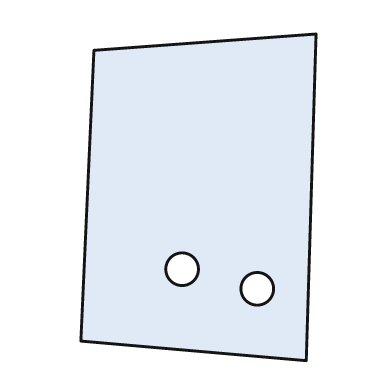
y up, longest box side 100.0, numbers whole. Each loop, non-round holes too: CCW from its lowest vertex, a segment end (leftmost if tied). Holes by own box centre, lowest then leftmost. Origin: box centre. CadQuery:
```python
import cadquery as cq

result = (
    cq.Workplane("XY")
    .moveTo(33.0, -50.0)
    .lineTo(36.0, 50.0)
    .lineTo(-32.0, 45.0)
    .lineTo(-36.0, -44.0)
    .close()
    .moveTo(18.0, -28.0)
    .circle(5.0)
    .moveTo(-5.0, -22.0)
    .circle(5.0)
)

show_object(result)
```